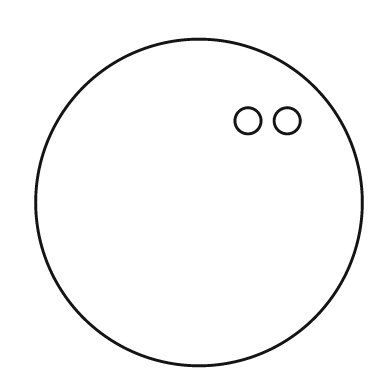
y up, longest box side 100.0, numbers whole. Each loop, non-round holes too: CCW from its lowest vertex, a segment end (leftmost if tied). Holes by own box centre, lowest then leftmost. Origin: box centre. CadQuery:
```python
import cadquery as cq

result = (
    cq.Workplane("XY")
    .moveTo(0.0, 0.0)
    .circle(50.0)
    .moveTo(15.0, 25.0)
    .circle(4.0)
    .moveTo(27.0, 25.0)
    .circle(4.0)
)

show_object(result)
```